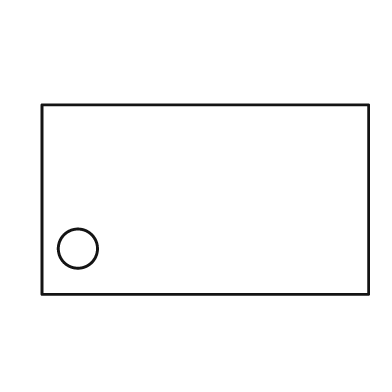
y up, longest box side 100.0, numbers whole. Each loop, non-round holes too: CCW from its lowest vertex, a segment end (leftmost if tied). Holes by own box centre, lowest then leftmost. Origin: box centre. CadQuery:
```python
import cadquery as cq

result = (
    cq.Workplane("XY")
    .moveTo(-50.0, -29.0)
    .lineTo(50.0, -29.0)
    .lineTo(50.0, 29.0)
    .lineTo(-50.0, 29.0)
    .close()
    .moveTo(-39.0, -15.0)
    .circle(6.0)
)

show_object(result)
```